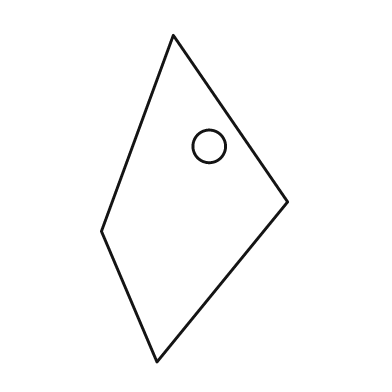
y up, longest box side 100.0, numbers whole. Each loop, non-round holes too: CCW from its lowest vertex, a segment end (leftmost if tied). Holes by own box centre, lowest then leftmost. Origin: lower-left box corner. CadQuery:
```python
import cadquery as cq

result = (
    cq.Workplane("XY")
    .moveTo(17.0, 0.0)
    .lineTo(57.0, 49.0)
    .lineTo(22.0, 100.0)
    .lineTo(0.0, 40.0)
    .close()
    .moveTo(33.0, 66.0)
    .circle(5.0)
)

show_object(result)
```